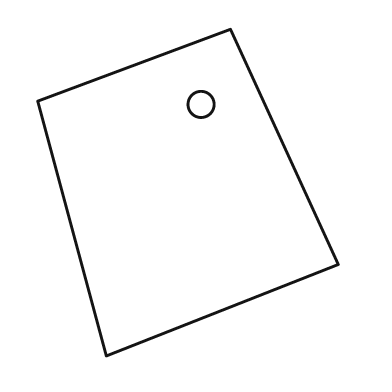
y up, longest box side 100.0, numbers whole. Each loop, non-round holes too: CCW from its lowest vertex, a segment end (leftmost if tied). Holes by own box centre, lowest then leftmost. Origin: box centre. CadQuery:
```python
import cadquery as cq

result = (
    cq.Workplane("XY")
    .moveTo(-25.0, -50.0)
    .lineTo(46.0, -22.0)
    .lineTo(13.0, 50.0)
    .lineTo(-46.0, 28.0)
    .close()
    .moveTo(4.0, 27.0)
    .circle(4.0)
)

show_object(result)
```